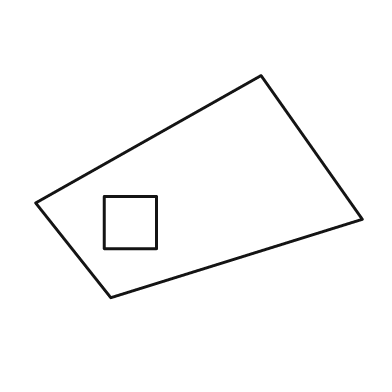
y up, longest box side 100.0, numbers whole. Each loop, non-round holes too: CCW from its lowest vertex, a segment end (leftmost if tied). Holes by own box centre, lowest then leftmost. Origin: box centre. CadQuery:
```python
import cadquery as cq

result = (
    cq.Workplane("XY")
    .moveTo(-27.0, -34.0)
    .lineTo(50.0, -10.0)
    .lineTo(19.0, 34.0)
    .lineTo(-50.0, -5.0)
    .close()
    .moveTo(-29.0, -19.0)
    .lineTo(-13.0, -19.0)
    .lineTo(-13.0, -3.0)
    .lineTo(-29.0, -3.0)
    .close()
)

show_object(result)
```